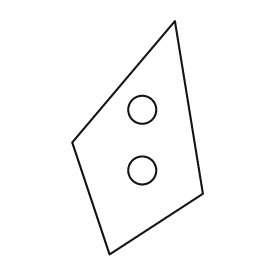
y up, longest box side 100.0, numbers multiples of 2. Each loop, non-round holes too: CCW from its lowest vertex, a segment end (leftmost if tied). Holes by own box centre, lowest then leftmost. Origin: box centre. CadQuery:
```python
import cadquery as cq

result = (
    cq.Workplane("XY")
    .moveTo(-12.0, -50.0)
    .lineTo(28.0, -24.0)
    .lineTo(16.0, 50.0)
    .lineTo(-28.0, -2.0)
    .close()
    .moveTo(2.0, -14.0)
    .circle(6.0)
    .moveTo(2.0, 12.0)
    .circle(6.0)
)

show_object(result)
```